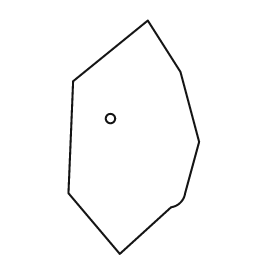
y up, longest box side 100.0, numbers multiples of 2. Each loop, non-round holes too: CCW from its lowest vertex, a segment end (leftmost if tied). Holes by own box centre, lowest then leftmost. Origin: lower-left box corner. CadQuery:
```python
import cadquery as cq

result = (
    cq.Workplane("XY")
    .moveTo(22.0, 0.0)
    .lineTo(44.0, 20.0)
    .threePointArc((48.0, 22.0), (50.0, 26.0))
    .lineTo(56.0, 48.0)
    .lineTo(48.0, 78.0)
    .lineTo(34.0, 100.0)
    .lineTo(2.0, 74.0)
    .lineTo(0.0, 26.0)
    .close()
    .moveTo(18.0, 58.0)
    .circle(2.0)
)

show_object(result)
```